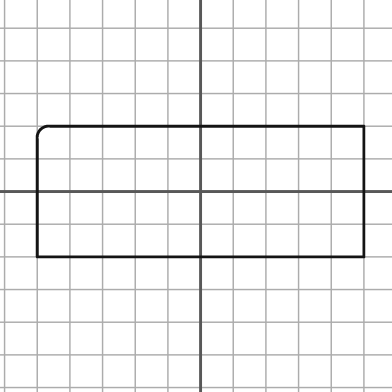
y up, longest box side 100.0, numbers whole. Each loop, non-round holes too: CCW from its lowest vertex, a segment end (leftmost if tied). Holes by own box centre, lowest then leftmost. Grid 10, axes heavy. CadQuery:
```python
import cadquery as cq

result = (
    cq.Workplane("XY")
    .moveTo(-50.0, -20.0)
    .lineTo(50.0, -20.0)
    .lineTo(50.0, 20.0)
    .lineTo(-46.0, 20.0)
    .threePointArc((-49.0, 19.0), (-50.0, 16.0))
    .close()
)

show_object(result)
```